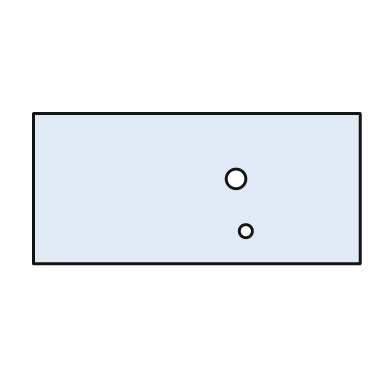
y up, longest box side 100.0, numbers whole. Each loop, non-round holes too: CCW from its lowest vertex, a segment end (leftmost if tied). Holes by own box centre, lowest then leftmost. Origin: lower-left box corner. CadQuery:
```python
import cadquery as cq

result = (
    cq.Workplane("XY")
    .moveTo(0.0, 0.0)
    .lineTo(100.0, 0.0)
    .lineTo(100.0, 46.0)
    .lineTo(0.0, 46.0)
    .close()
    .moveTo(65.0, 10.0)
    .circle(2.0)
    .moveTo(62.0, 26.0)
    .circle(3.0)
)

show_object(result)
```